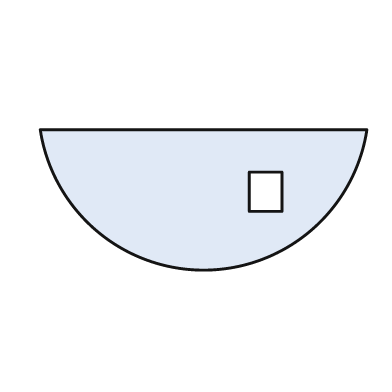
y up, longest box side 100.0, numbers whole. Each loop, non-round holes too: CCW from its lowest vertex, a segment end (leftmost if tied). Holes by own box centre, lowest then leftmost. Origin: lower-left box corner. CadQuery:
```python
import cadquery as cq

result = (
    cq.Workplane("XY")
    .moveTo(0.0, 43.0)
    .threePointArc((50.0, 0.0), (100.0, 43.0))
    .close()
    .moveTo(64.0, 18.0)
    .lineTo(74.0, 18.0)
    .lineTo(74.0, 30.0)
    .lineTo(64.0, 30.0)
    .close()
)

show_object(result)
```